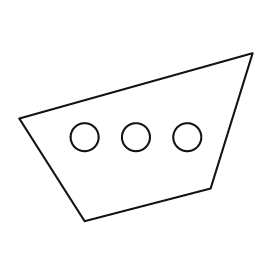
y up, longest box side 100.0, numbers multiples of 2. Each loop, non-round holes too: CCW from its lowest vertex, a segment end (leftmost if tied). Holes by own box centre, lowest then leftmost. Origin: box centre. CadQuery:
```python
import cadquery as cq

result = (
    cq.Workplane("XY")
    .moveTo(-22.0, -36.0)
    .lineTo(32.0, -22.0)
    .lineTo(50.0, 36.0)
    .lineTo(-50.0, 8.0)
    .close()
    .moveTo(-22.0, 0.0)
    .circle(6.0)
    .moveTo(0.0, 0.0)
    .circle(6.0)
    .moveTo(22.0, 0.0)
    .circle(6.0)
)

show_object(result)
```